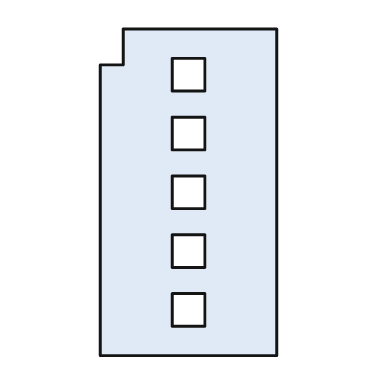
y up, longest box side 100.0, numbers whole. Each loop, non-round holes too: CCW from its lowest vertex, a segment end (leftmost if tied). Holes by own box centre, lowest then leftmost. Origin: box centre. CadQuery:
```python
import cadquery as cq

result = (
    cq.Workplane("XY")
    .moveTo(-27.0, -50.0)
    .lineTo(27.0, -50.0)
    .lineTo(27.0, 50.0)
    .lineTo(-20.0, 50.0)
    .lineTo(-20.0, 39.0)
    .lineTo(-27.0, 39.0)
    .close()
    .moveTo(-5.0, -41.0)
    .lineTo(5.0, -41.0)
    .lineTo(5.0, -31.0)
    .lineTo(-5.0, -31.0)
    .close()
    .moveTo(-5.0, -23.0)
    .lineTo(5.0, -23.0)
    .lineTo(5.0, -13.0)
    .lineTo(-5.0, -13.0)
    .close()
    .moveTo(-5.0, -5.0)
    .lineTo(5.0, -5.0)
    .lineTo(5.0, 5.0)
    .lineTo(-5.0, 5.0)
    .close()
    .moveTo(-5.0, 13.0)
    .lineTo(5.0, 13.0)
    .lineTo(5.0, 23.0)
    .lineTo(-5.0, 23.0)
    .close()
    .moveTo(-5.0, 31.0)
    .lineTo(5.0, 31.0)
    .lineTo(5.0, 41.0)
    .lineTo(-5.0, 41.0)
    .close()
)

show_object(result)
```